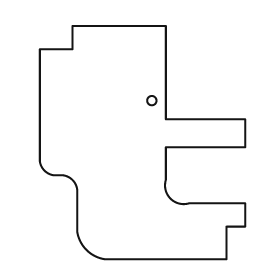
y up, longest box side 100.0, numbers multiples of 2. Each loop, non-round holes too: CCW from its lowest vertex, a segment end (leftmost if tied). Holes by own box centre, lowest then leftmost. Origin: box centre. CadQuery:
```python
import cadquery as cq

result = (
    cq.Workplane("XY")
    .moveTo(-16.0, -50.0)
    .lineTo(36.0, -50.0)
    .lineTo(36.0, -36.0)
    .lineTo(44.0, -36.0)
    .lineTo(44.0, -26.0)
    .lineTo(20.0, -26.0)
    .threePointArc((12.0, -24.0), (10.0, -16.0))
    .lineTo(10.0, -2.0)
    .lineTo(44.0, -2.0)
    .lineTo(44.0, 10.0)
    .lineTo(10.0, 10.0)
    .lineTo(10.0, 50.0)
    .lineTo(-30.0, 50.0)
    .lineTo(-30.0, 40.0)
    .lineTo(-44.0, 40.0)
    .lineTo(-44.0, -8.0)
    .threePointArc((-42.0, -12.0), (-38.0, -14.0))
    .lineTo(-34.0, -14.0)
    .threePointArc((-30.0, -16.0), (-28.0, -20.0))
    .lineTo(-28.0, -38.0)
    .threePointArc((-24.0, -46.0), (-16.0, -50.0))
    .close()
    .moveTo(4.0, 18.0)
    .circle(2.0)
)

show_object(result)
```